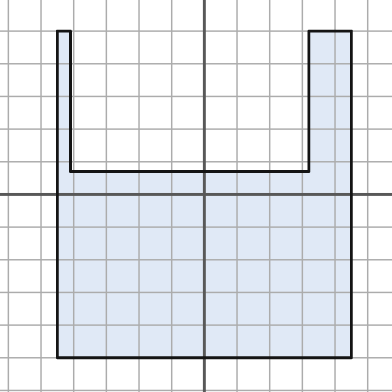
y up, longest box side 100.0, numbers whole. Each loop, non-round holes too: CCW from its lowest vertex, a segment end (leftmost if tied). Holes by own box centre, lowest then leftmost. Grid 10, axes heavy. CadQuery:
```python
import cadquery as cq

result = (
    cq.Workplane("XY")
    .moveTo(-45.0, -50.0)
    .lineTo(45.0, -50.0)
    .lineTo(45.0, 50.0)
    .lineTo(32.0, 50.0)
    .lineTo(32.0, 7.0)
    .lineTo(-41.0, 7.0)
    .lineTo(-41.0, 50.0)
    .lineTo(-45.0, 50.0)
    .close()
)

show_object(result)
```